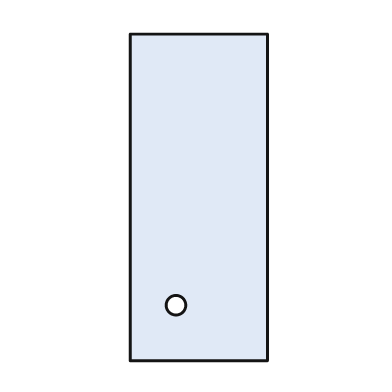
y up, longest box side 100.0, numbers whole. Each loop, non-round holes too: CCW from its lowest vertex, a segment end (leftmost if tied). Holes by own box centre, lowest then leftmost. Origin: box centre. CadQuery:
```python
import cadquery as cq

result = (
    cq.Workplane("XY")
    .moveTo(-21.0, -50.0)
    .lineTo(21.0, -50.0)
    .lineTo(21.0, 50.0)
    .lineTo(-21.0, 50.0)
    .close()
    .moveTo(-7.0, -33.0)
    .circle(3.0)
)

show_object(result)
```